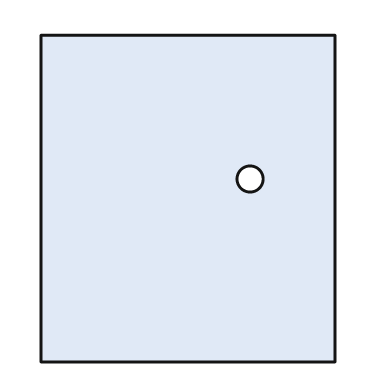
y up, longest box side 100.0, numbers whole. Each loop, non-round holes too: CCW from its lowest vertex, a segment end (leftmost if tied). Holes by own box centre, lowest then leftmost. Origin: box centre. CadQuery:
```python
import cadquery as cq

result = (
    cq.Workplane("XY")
    .moveTo(-45.0, -50.0)
    .lineTo(45.0, -50.0)
    .lineTo(45.0, 50.0)
    .lineTo(-45.0, 50.0)
    .close()
    .moveTo(19.0, 6.0)
    .circle(4.0)
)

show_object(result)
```